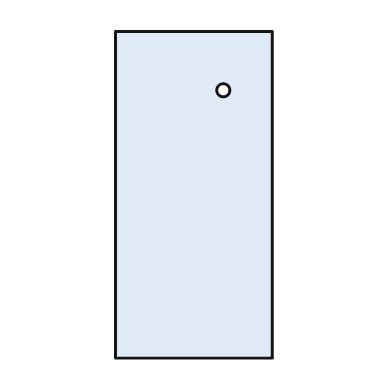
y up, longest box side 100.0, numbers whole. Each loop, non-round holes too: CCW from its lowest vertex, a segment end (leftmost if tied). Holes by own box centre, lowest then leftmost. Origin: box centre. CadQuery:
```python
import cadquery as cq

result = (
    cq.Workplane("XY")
    .moveTo(-24.0, -50.0)
    .lineTo(24.0, -50.0)
    .lineTo(24.0, 50.0)
    .lineTo(-24.0, 50.0)
    .close()
    .moveTo(9.0, 32.0)
    .circle(2.0)
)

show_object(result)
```